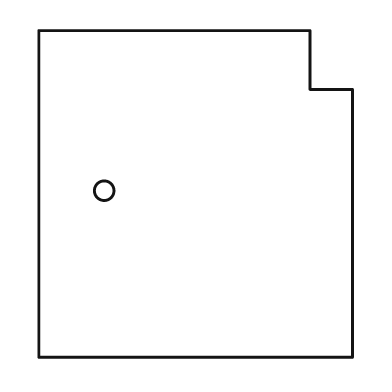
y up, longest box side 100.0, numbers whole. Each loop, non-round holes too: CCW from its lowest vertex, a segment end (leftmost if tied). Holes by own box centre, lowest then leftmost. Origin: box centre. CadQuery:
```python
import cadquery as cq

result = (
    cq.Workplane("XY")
    .moveTo(-48.0, -50.0)
    .lineTo(48.0, -50.0)
    .lineTo(48.0, 32.0)
    .lineTo(35.0, 32.0)
    .lineTo(35.0, 50.0)
    .lineTo(-48.0, 50.0)
    .close()
    .moveTo(-28.0, 1.0)
    .circle(3.0)
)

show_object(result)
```